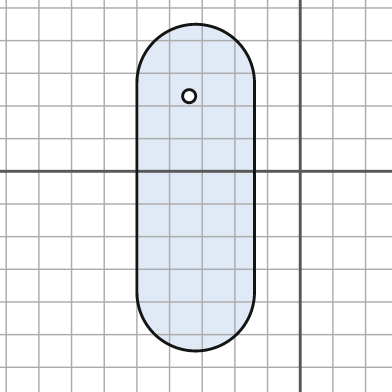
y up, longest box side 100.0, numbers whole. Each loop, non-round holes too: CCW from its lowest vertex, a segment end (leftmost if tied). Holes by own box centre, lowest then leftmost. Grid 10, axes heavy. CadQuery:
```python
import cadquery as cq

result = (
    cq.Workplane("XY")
    .moveTo(-50.0, -37.0)
    .threePointArc((-32.0, -55.0), (-14.0, -37.0))
    .lineTo(-14.0, 27.0)
    .threePointArc((-32.0, 45.0), (-50.0, 27.0))
    .close()
    .moveTo(-34.0, 23.0)
    .circle(2.0)
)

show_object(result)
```